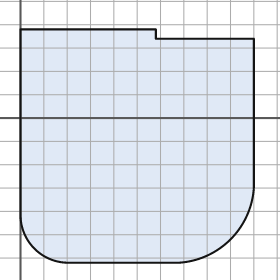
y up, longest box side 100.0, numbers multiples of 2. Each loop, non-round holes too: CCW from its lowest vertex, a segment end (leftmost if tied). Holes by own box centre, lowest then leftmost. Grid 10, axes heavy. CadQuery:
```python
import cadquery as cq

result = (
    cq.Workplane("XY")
    .moveTo(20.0, -62.0)
    .lineTo(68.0, -62.0)
    .threePointArc((90.0, -52.0), (100.0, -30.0))
    .lineTo(100.0, 34.0)
    .lineTo(58.0, 34.0)
    .lineTo(58.0, 38.0)
    .lineTo(0.0, 38.0)
    .lineTo(0.0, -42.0)
    .threePointArc((6.0, -56.0), (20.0, -62.0))
    .close()
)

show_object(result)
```